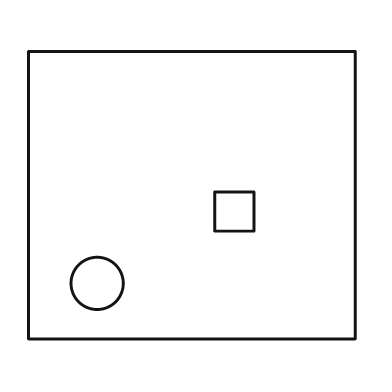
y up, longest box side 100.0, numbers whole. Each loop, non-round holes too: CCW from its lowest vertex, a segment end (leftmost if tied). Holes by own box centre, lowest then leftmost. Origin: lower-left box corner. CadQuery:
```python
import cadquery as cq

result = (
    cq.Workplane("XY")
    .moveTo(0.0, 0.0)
    .lineTo(100.0, 0.0)
    .lineTo(100.0, 88.0)
    .lineTo(0.0, 88.0)
    .close()
    .moveTo(21.0, 17.0)
    .circle(8.0)
    .moveTo(57.0, 33.0)
    .lineTo(69.0, 33.0)
    .lineTo(69.0, 45.0)
    .lineTo(57.0, 45.0)
    .close()
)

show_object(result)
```